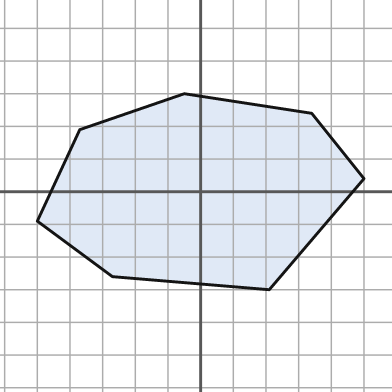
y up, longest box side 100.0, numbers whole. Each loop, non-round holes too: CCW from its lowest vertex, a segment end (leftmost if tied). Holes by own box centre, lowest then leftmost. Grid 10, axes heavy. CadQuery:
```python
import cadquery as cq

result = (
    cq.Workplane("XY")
    .moveTo(21.0, -30.0)
    .lineTo(50.0, 4.0)
    .lineTo(34.0, 24.0)
    .lineTo(-5.0, 30.0)
    .lineTo(-37.0, 19.0)
    .lineTo(-50.0, -9.0)
    .lineTo(-27.0, -26.0)
    .close()
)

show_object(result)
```